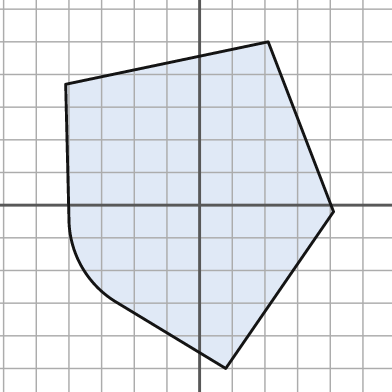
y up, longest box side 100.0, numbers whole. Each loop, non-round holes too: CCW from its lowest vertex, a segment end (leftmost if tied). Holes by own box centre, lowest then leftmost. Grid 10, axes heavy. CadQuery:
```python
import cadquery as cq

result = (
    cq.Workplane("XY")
    .moveTo(8.0, -50.0)
    .lineTo(41.0, -2.0)
    .lineTo(21.0, 50.0)
    .lineTo(-41.0, 37.0)
    .lineTo(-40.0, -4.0)
    .threePointArc((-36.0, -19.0), (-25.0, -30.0))
    .close()
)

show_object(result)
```